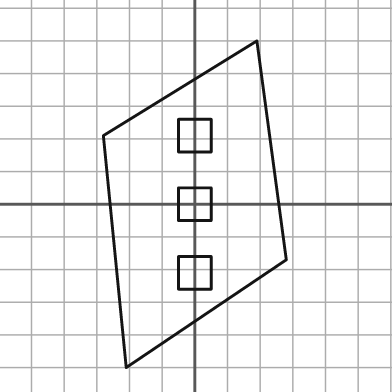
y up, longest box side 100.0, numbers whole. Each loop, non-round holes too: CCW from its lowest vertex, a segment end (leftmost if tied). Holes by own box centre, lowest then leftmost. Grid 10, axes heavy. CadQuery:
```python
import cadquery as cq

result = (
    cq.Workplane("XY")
    .moveTo(-21.0, -50.0)
    .lineTo(28.0, -17.0)
    .lineTo(19.0, 50.0)
    .lineTo(-28.0, 21.0)
    .close()
    .moveTo(-5.0, -26.0)
    .lineTo(5.0, -26.0)
    .lineTo(5.0, -16.0)
    .lineTo(-5.0, -16.0)
    .close()
    .moveTo(-5.0, -5.0)
    .lineTo(5.0, -5.0)
    .lineTo(5.0, 5.0)
    .lineTo(-5.0, 5.0)
    .close()
    .moveTo(-5.0, 16.0)
    .lineTo(5.0, 16.0)
    .lineTo(5.0, 26.0)
    .lineTo(-5.0, 26.0)
    .close()
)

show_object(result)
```